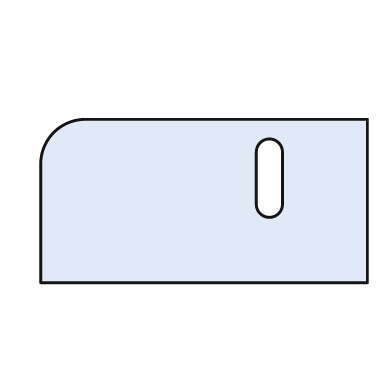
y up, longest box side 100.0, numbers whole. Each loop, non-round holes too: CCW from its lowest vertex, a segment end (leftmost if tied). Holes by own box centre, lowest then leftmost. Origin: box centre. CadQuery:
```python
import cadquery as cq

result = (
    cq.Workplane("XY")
    .moveTo(-50.0, -25.0)
    .lineTo(50.0, -25.0)
    .lineTo(50.0, 25.0)
    .lineTo(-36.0, 25.0)
    .threePointArc((-46.0, 21.0), (-50.0, 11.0))
    .close()
    .moveTo(16.0, -1.0)
    .threePointArc((20.0, -5.0), (24.0, -1.0))
    .lineTo(24.0, 15.0)
    .threePointArc((20.0, 19.0), (16.0, 15.0))
    .close()
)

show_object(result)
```